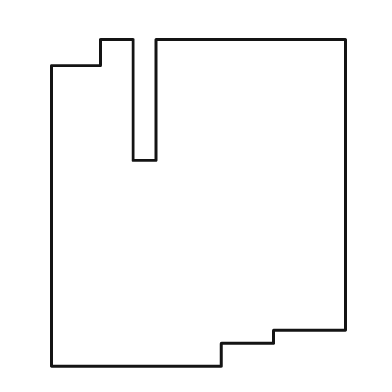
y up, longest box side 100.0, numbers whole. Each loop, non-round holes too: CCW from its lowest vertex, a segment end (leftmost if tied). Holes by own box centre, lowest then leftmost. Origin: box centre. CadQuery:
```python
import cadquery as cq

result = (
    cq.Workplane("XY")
    .moveTo(-45.0, -50.0)
    .lineTo(7.0, -50.0)
    .lineTo(7.0, -43.0)
    .lineTo(23.0, -43.0)
    .lineTo(23.0, -39.0)
    .lineTo(45.0, -39.0)
    .lineTo(45.0, 50.0)
    .lineTo(-13.0, 50.0)
    .lineTo(-13.0, 13.0)
    .lineTo(-20.0, 13.0)
    .lineTo(-20.0, 50.0)
    .lineTo(-30.0, 50.0)
    .lineTo(-30.0, 42.0)
    .lineTo(-45.0, 42.0)
    .close()
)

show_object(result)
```